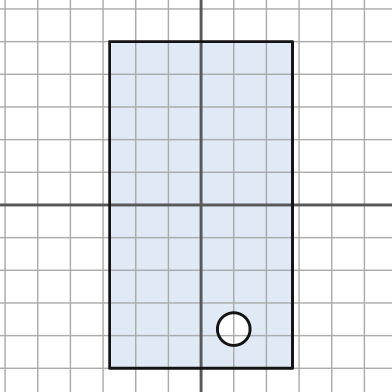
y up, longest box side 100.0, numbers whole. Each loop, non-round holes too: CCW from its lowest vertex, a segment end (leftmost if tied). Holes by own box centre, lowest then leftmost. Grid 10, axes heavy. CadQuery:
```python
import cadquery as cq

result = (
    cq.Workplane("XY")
    .moveTo(-28.0, -50.0)
    .lineTo(28.0, -50.0)
    .lineTo(28.0, 50.0)
    .lineTo(-28.0, 50.0)
    .close()
    .moveTo(10.0, -38.0)
    .circle(5.0)
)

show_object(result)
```